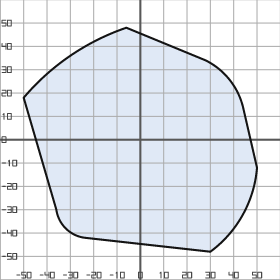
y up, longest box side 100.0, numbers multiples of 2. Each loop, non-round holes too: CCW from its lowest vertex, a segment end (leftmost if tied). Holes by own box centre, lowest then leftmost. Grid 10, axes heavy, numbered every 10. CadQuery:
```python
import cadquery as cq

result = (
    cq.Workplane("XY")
    .moveTo(30.0, -48.0)
    .threePointArc((44.0, -32.0), (50.0, -12.0))
    .lineTo(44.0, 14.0)
    .threePointArc((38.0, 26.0), (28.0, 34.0))
    .lineTo(-6.0, 48.0)
    .threePointArc((-30.0, 36.0), (-50.0, 18.0))
    .lineTo(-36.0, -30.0)
    .threePointArc((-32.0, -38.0), (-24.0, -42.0))
    .close()
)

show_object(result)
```